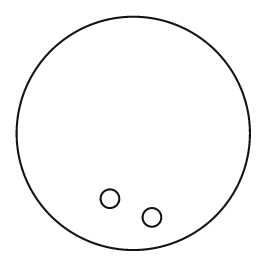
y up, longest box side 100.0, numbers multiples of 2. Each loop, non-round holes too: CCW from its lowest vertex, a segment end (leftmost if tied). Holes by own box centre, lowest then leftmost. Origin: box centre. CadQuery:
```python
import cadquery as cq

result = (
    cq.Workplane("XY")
    .moveTo(0.0, 0.0)
    .circle(50.0)
    .moveTo(8.0, -36.0)
    .circle(4.0)
    .moveTo(-10.0, -28.0)
    .circle(4.0)
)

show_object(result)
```